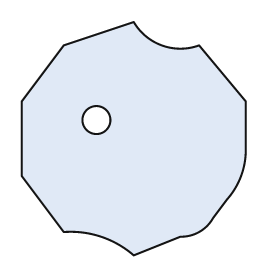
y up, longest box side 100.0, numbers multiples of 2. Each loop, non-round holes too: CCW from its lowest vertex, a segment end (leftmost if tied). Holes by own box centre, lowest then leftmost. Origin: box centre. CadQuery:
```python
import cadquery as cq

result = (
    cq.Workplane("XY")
    .moveTo(0.0, -50.0)
    .lineTo(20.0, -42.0)
    .threePointArc((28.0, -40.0), (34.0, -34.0))
    .lineTo(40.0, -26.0)
    .threePointArc((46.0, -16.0), (48.0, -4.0))
    .lineTo(48.0, 16.0)
    .lineTo(28.0, 40.0)
    .threePointArc((12.0, 40.0), (0.0, 50.0))
    .lineTo(-30.0, 40.0)
    .lineTo(-48.0, 16.0)
    .lineTo(-48.0, -16.0)
    .lineTo(-30.0, -40.0)
    .threePointArc((-14.0, -42.0), (0.0, -50.0))
    .close()
    .moveTo(-16.0, 8.0)
    .circle(6.0)
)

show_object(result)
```